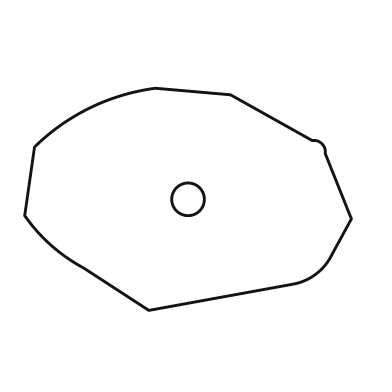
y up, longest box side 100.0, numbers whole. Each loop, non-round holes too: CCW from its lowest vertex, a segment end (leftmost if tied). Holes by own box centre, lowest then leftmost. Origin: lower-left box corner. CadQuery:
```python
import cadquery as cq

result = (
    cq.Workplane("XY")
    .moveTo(38.0, 0.0)
    .lineTo(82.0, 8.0)
    .threePointArc((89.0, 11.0), (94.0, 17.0))
    .lineTo(100.0, 28.0)
    .lineTo(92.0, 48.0)
    .threePointArc((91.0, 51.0), (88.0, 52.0))
    .lineTo(63.0, 66.0)
    .lineTo(40.0, 68.0)
    .threePointArc((20.0, 62.0), (3.0, 50.0))
    .lineTo(0.0, 29.0)
    .threePointArc((8.0, 20.0), (18.0, 13.0))
    .close()
    .moveTo(50.0, 34.0)
    .circle(5.0)
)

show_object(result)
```